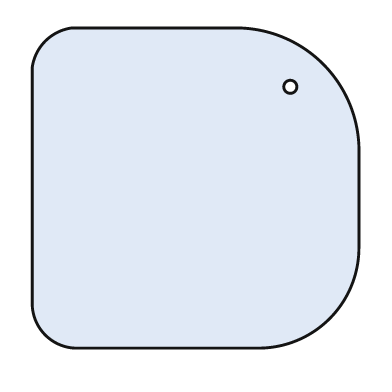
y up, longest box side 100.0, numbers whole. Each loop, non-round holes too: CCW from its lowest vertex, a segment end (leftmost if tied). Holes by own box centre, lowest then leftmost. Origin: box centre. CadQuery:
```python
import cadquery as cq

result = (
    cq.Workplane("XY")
    .moveTo(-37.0, -49.0)
    .lineTo(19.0, -49.0)
    .threePointArc((41.0, -40.0), (50.0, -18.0))
    .lineTo(50.0, 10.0)
    .threePointArc((39.0, 38.0), (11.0, 49.0))
    .lineTo(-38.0, 49.0)
    .threePointArc((-46.0, 45.0), (-50.0, 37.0))
    .lineTo(-50.0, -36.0)
    .threePointArc((-46.0, -45.0), (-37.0, -49.0))
    .close()
    .moveTo(29.0, 31.0)
    .circle(2.0)
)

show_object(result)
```